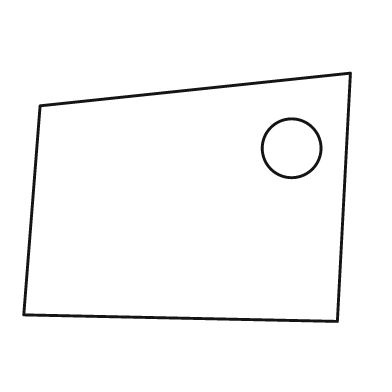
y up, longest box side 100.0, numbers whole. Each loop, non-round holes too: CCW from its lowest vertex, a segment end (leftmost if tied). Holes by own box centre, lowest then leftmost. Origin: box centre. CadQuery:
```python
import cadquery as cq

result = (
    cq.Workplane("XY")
    .moveTo(46.0, -38.0)
    .lineTo(50.0, 38.0)
    .lineTo(-45.0, 28.0)
    .lineTo(-50.0, -36.0)
    .close()
    .moveTo(32.0, 15.0)
    .circle(9.0)
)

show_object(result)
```